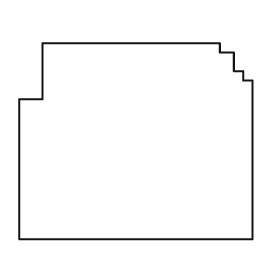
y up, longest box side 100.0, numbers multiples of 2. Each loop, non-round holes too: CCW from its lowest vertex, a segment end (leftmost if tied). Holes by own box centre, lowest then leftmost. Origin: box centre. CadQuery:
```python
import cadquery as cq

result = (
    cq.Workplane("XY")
    .moveTo(-50.0, -42.0)
    .lineTo(50.0, -42.0)
    .lineTo(50.0, 26.0)
    .lineTo(46.0, 26.0)
    .lineTo(46.0, 30.0)
    .lineTo(42.0, 30.0)
    .lineTo(42.0, 38.0)
    .lineTo(36.0, 38.0)
    .lineTo(36.0, 42.0)
    .lineTo(-40.0, 42.0)
    .lineTo(-40.0, 18.0)
    .lineTo(-50.0, 18.0)
    .close()
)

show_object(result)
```